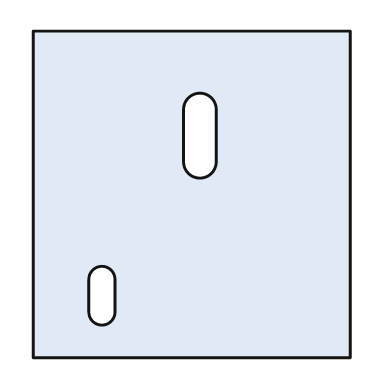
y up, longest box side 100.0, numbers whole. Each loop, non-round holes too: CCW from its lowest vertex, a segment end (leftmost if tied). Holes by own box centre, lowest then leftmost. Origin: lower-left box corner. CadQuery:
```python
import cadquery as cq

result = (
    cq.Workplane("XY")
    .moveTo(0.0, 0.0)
    .lineTo(97.0, 0.0)
    .lineTo(97.0, 100.0)
    .lineTo(0.0, 100.0)
    .close()
    .moveTo(17.0, 14.0)
    .threePointArc((21.0, 10.0), (25.0, 14.0))
    .lineTo(25.0, 24.0)
    .threePointArc((21.0, 28.0), (17.0, 24.0))
    .close()
    .moveTo(46.0, 60.0)
    .threePointArc((51.0, 55.0), (56.0, 60.0))
    .lineTo(56.0, 76.0)
    .threePointArc((51.0, 81.0), (46.0, 76.0))
    .close()
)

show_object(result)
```